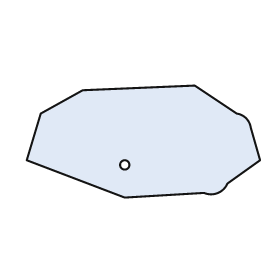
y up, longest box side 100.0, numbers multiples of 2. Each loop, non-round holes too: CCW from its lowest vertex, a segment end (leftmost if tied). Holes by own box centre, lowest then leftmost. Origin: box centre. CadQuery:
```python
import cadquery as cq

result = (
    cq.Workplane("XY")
    .moveTo(-8.0, -24.0)
    .lineTo(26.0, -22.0)
    .threePointArc((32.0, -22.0), (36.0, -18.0))
    .lineTo(50.0, -8.0)
    .lineTo(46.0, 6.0)
    .threePointArc((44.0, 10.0), (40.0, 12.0))
    .lineTo(22.0, 24.0)
    .lineTo(-26.0, 22.0)
    .lineTo(-44.0, 12.0)
    .lineTo(-50.0, -8.0)
    .close()
    .moveTo(-8.0, -10.0)
    .circle(2.0)
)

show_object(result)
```